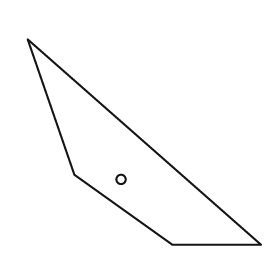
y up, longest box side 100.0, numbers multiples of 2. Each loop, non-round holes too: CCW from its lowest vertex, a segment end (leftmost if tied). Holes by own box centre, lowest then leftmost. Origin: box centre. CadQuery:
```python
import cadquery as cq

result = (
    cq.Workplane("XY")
    .moveTo(12.0, -44.0)
    .lineTo(50.0, -44.0)
    .lineTo(-50.0, 44.0)
    .lineTo(-30.0, -14.0)
    .close()
    .moveTo(-10.0, -16.0)
    .circle(2.0)
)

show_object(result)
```